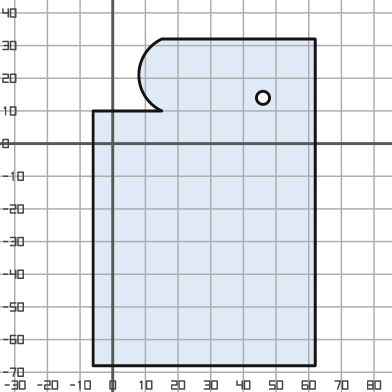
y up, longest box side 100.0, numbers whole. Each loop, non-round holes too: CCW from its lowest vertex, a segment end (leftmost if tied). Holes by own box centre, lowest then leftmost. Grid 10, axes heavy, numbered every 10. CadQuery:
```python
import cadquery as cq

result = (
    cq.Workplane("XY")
    .moveTo(-6.0, -68.0)
    .lineTo(62.0, -68.0)
    .lineTo(62.0, 32.0)
    .lineTo(15.0, 32.0)
    .threePointArc((8.0, 21.0), (15.0, 10.0))
    .lineTo(-6.0, 10.0)
    .close()
    .moveTo(46.0, 14.0)
    .circle(2.0)
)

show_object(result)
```